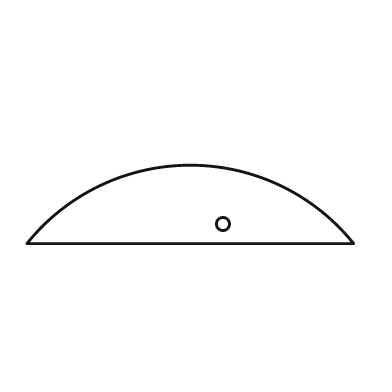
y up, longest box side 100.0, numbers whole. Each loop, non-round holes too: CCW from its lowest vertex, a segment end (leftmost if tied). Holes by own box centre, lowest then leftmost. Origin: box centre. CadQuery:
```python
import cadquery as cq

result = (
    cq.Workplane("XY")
    .moveTo(-50.0, -12.0)
    .lineTo(50.0, -12.0)
    .threePointArc((0.0, 12.0), (-50.0, -12.0))
    .close()
    .moveTo(10.0, -6.0)
    .circle(2.0)
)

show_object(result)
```